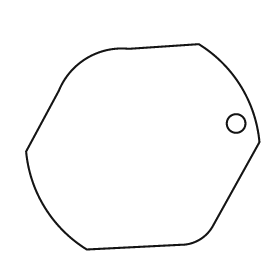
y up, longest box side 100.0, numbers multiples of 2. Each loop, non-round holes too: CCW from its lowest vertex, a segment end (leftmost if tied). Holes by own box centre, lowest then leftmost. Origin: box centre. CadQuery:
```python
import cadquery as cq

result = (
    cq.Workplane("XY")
    .moveTo(-24.0, -44.0)
    .lineTo(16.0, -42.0)
    .threePointArc((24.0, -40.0), (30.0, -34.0))
    .lineTo(50.0, 2.0)
    .threePointArc((42.0, 26.0), (24.0, 44.0))
    .lineTo(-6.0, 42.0)
    .threePointArc((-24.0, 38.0), (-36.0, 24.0))
    .lineTo(-50.0, -2.0)
    .threePointArc((-42.0, -26.0), (-24.0, -44.0))
    .close()
    .moveTo(40.0, 10.0)
    .circle(4.0)
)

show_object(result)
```